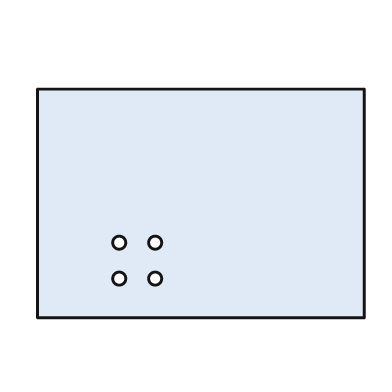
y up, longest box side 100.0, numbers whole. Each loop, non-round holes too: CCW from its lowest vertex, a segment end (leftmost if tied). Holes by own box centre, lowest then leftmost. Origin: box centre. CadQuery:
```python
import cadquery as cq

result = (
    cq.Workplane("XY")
    .moveTo(-50.0, -35.0)
    .lineTo(50.0, -35.0)
    .lineTo(50.0, 35.0)
    .lineTo(-50.0, 35.0)
    .close()
    .moveTo(-25.0, -23.0)
    .circle(2.0)
    .moveTo(-14.0, -23.0)
    .circle(2.0)
    .moveTo(-25.0, -12.0)
    .circle(2.0)
    .moveTo(-14.0, -12.0)
    .circle(2.0)
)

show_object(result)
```